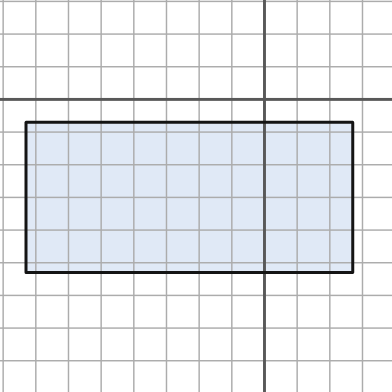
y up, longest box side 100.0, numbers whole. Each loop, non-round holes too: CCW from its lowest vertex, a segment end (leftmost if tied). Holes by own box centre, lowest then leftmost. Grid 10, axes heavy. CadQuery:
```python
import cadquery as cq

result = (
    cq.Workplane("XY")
    .moveTo(-73.0, -53.0)
    .lineTo(27.0, -53.0)
    .lineTo(27.0, -7.0)
    .lineTo(-73.0, -7.0)
    .close()
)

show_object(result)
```